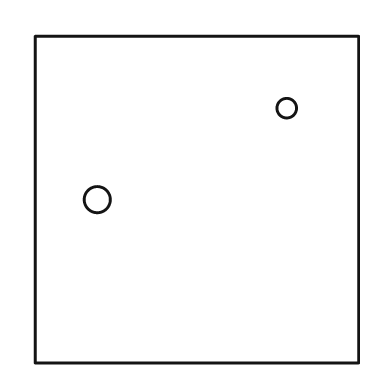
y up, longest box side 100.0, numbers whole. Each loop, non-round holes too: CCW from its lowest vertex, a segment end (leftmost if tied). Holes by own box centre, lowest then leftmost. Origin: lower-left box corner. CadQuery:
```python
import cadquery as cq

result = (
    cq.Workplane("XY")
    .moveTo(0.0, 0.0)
    .lineTo(99.0, 0.0)
    .lineTo(99.0, 100.0)
    .lineTo(0.0, 100.0)
    .close()
    .moveTo(19.0, 50.0)
    .circle(4.0)
    .moveTo(77.0, 78.0)
    .circle(3.0)
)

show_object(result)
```